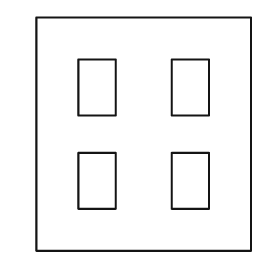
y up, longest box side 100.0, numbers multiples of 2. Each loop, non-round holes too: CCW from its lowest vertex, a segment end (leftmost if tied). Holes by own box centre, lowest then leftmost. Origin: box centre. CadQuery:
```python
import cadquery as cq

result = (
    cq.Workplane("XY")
    .moveTo(-46.0, -50.0)
    .lineTo(46.0, -50.0)
    .lineTo(46.0, 50.0)
    .lineTo(-46.0, 50.0)
    .close()
    .moveTo(-28.0, -32.0)
    .lineTo(-12.0, -32.0)
    .lineTo(-12.0, -8.0)
    .lineTo(-28.0, -8.0)
    .close()
    .moveTo(12.0, -32.0)
    .lineTo(28.0, -32.0)
    .lineTo(28.0, -8.0)
    .lineTo(12.0, -8.0)
    .close()
    .moveTo(-28.0, 8.0)
    .lineTo(-12.0, 8.0)
    .lineTo(-12.0, 32.0)
    .lineTo(-28.0, 32.0)
    .close()
    .moveTo(12.0, 8.0)
    .lineTo(28.0, 8.0)
    .lineTo(28.0, 32.0)
    .lineTo(12.0, 32.0)
    .close()
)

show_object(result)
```